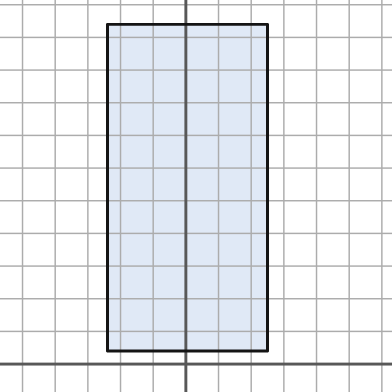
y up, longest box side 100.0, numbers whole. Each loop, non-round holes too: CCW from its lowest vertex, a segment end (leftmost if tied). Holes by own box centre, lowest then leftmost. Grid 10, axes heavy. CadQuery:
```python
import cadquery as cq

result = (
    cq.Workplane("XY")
    .moveTo(-24.0, 4.0)
    .lineTo(25.0, 4.0)
    .lineTo(25.0, 104.0)
    .lineTo(-24.0, 104.0)
    .close()
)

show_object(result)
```